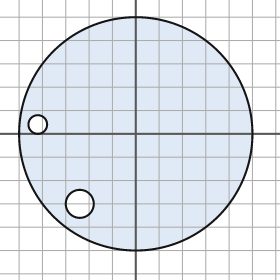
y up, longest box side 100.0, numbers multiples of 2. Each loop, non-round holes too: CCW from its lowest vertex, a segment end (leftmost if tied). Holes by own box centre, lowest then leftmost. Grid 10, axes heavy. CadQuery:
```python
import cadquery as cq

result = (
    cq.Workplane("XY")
    .moveTo(0.0, 0.0)
    .circle(50.0)
    .moveTo(-24.0, -30.0)
    .circle(6.0)
    .moveTo(-42.0, 4.0)
    .circle(4.0)
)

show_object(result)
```